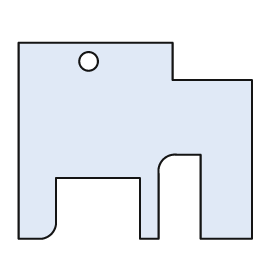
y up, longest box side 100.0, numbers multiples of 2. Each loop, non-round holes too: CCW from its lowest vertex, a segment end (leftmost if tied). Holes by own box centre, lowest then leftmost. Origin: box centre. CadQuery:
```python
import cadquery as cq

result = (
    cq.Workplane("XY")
    .moveTo(-50.0, -42.0)
    .lineTo(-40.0, -42.0)
    .threePointArc((-36.0, -40.0), (-34.0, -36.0))
    .lineTo(-34.0, -16.0)
    .lineTo(2.0, -16.0)
    .lineTo(2.0, -42.0)
    .lineTo(10.0, -42.0)
    .lineTo(10.0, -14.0)
    .threePointArc((12.0, -8.0), (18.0, -6.0))
    .lineTo(28.0, -6.0)
    .lineTo(28.0, -42.0)
    .lineTo(50.0, -42.0)
    .lineTo(50.0, 26.0)
    .lineTo(16.0, 26.0)
    .lineTo(16.0, 42.0)
    .lineTo(-50.0, 42.0)
    .close()
    .moveTo(-20.0, 34.0)
    .circle(4.0)
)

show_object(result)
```